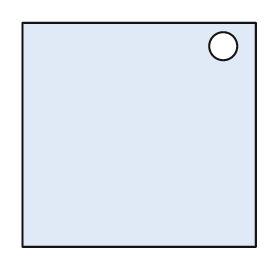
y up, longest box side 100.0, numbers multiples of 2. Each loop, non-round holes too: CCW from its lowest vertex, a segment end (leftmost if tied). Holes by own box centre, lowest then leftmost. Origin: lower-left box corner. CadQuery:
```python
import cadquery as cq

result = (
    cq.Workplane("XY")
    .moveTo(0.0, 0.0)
    .lineTo(100.0, 0.0)
    .lineTo(100.0, 96.0)
    .lineTo(0.0, 96.0)
    .close()
    .moveTo(86.0, 86.0)
    .circle(6.0)
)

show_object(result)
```